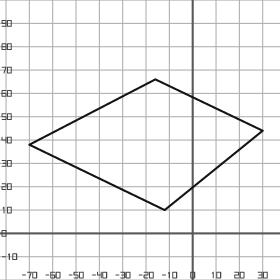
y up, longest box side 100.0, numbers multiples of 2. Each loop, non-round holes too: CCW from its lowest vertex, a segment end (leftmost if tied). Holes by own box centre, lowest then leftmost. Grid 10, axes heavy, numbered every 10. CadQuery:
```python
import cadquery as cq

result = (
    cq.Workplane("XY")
    .moveTo(-12.0, 10.0)
    .lineTo(30.0, 44.0)
    .lineTo(-16.0, 66.0)
    .lineTo(-70.0, 38.0)
    .close()
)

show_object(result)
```